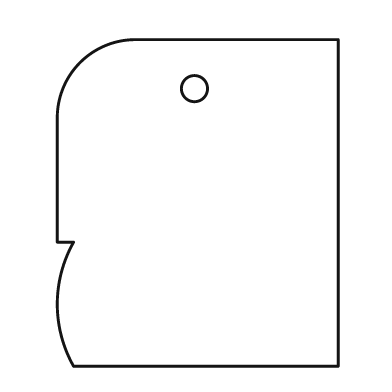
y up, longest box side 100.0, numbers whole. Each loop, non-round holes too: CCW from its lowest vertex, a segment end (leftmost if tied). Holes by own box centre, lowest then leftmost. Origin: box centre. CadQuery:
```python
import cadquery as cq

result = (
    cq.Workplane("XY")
    .moveTo(-38.0, -50.0)
    .lineTo(43.0, -50.0)
    .lineTo(43.0, 50.0)
    .lineTo(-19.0, 50.0)
    .threePointArc((-36.0, 43.0), (-43.0, 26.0))
    .lineTo(-43.0, -12.0)
    .lineTo(-38.0, -12.0)
    .threePointArc((-43.0, -31.0), (-38.0, -50.0))
    .close()
    .moveTo(-1.0, 35.0)
    .circle(4.0)
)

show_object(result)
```